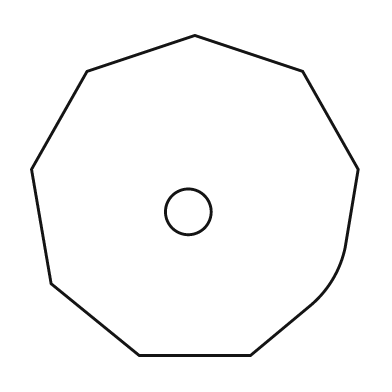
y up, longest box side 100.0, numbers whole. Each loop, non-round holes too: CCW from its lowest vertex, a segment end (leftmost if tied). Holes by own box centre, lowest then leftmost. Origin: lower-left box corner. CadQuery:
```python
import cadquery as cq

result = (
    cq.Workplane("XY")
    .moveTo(33.0, 0.0)
    .lineTo(67.0, 0.0)
    .lineTo(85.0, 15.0)
    .threePointArc((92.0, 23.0), (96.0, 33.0))
    .lineTo(100.0, 57.0)
    .lineTo(83.0, 87.0)
    .lineTo(50.0, 98.0)
    .lineTo(17.0, 87.0)
    .lineTo(0.0, 57.0)
    .lineTo(6.0, 22.0)
    .close()
    .moveTo(48.0, 44.0)
    .circle(7.0)
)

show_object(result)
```